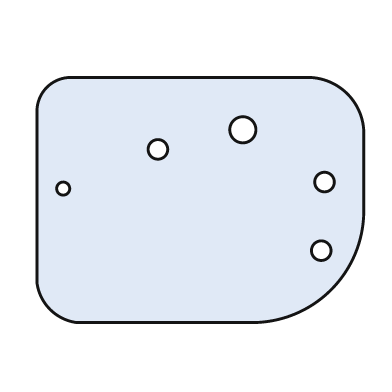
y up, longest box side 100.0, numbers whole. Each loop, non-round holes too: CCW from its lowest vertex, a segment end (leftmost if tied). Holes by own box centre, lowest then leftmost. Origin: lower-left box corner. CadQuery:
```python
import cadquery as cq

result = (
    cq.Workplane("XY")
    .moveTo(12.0, 0.0)
    .lineTo(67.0, 0.0)
    .threePointArc((90.0, 10.0), (100.0, 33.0))
    .lineTo(100.0, 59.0)
    .threePointArc((95.0, 70.0), (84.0, 75.0))
    .lineTo(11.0, 75.0)
    .threePointArc((3.0, 72.0), (0.0, 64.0))
    .lineTo(0.0, 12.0)
    .threePointArc((4.0, 4.0), (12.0, 0.0))
    .close()
    .moveTo(87.0, 22.0)
    .circle(3.0)
    .moveTo(8.0, 41.0)
    .circle(2.0)
    .moveTo(88.0, 43.0)
    .circle(3.0)
    .moveTo(37.0, 53.0)
    .circle(3.0)
    .moveTo(63.0, 59.0)
    .circle(4.0)
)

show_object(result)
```